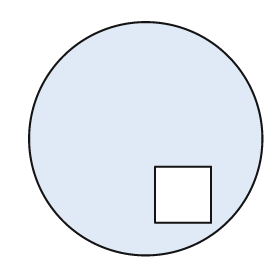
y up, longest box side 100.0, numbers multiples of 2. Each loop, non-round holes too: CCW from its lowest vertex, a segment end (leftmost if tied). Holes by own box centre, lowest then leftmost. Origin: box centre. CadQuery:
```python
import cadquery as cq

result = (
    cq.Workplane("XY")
    .moveTo(0.0, 0.0)
    .circle(50.0)
    .moveTo(4.0, -36.0)
    .lineTo(28.0, -36.0)
    .lineTo(28.0, -12.0)
    .lineTo(4.0, -12.0)
    .close()
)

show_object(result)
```